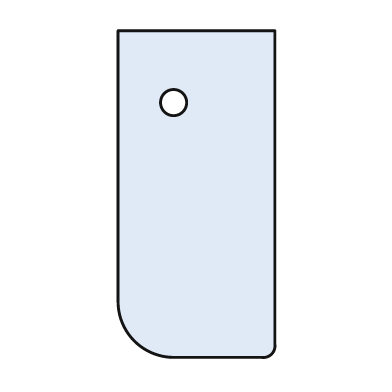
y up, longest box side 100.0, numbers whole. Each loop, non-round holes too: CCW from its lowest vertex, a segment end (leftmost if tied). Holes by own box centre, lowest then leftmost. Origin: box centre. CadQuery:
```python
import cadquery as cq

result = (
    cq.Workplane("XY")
    .moveTo(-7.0, -50.0)
    .lineTo(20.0, -50.0)
    .threePointArc((23.0, -49.0), (24.0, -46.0))
    .lineTo(24.0, 50.0)
    .lineTo(-24.0, 50.0)
    .lineTo(-24.0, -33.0)
    .threePointArc((-19.0, -45.0), (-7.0, -50.0))
    .close()
    .moveTo(-7.0, 28.0)
    .circle(4.0)
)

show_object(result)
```